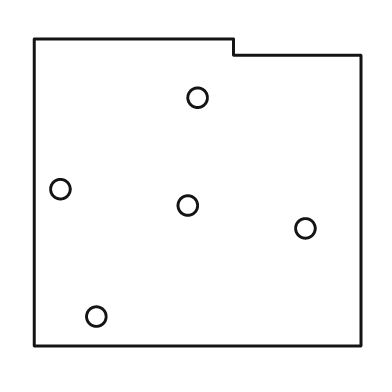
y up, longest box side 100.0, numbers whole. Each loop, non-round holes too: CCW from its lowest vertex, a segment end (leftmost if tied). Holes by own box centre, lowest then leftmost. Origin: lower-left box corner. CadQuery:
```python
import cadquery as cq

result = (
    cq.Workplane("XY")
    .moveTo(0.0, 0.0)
    .lineTo(100.0, 0.0)
    .lineTo(100.0, 89.0)
    .lineTo(61.0, 89.0)
    .lineTo(61.0, 94.0)
    .lineTo(0.0, 94.0)
    .close()
    .moveTo(19.0, 9.0)
    .circle(3.0)
    .moveTo(83.0, 36.0)
    .circle(3.0)
    .moveTo(47.0, 43.0)
    .circle(3.0)
    .moveTo(8.0, 48.0)
    .circle(3.0)
    .moveTo(50.0, 76.0)
    .circle(3.0)
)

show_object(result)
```